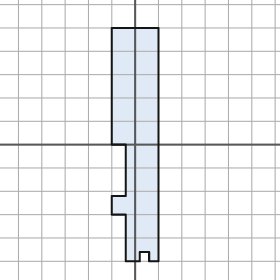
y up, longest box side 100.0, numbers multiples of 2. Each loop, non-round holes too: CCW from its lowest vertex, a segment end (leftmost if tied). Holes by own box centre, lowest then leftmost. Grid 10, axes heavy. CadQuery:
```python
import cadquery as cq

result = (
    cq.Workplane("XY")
    .moveTo(-4.0, -50.0)
    .lineTo(2.0, -50.0)
    .lineTo(2.0, -46.0)
    .lineTo(6.0, -46.0)
    .lineTo(6.0, -50.0)
    .lineTo(10.0, -50.0)
    .lineTo(10.0, 50.0)
    .lineTo(-10.0, 50.0)
    .lineTo(-10.0, 0.0)
    .lineTo(-4.0, 0.0)
    .lineTo(-4.0, -22.0)
    .lineTo(-10.0, -22.0)
    .lineTo(-10.0, -30.0)
    .lineTo(-4.0, -30.0)
    .close()
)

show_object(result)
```